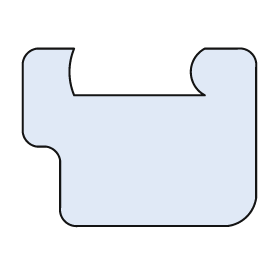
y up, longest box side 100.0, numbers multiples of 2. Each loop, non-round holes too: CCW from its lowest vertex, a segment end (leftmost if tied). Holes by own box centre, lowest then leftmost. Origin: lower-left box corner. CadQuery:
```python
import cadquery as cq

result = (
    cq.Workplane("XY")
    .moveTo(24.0, 0.0)
    .lineTo(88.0, 0.0)
    .threePointArc((96.0, 4.0), (100.0, 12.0))
    .lineTo(100.0, 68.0)
    .threePointArc((98.0, 74.0), (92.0, 76.0))
    .lineTo(78.0, 76.0)
    .threePointArc((72.0, 66.0), (78.0, 56.0))
    .lineTo(22.0, 56.0)
    .threePointArc((20.0, 66.0), (22.0, 76.0))
    .lineTo(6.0, 76.0)
    .threePointArc((2.0, 74.0), (0.0, 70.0))
    .lineTo(0.0, 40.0)
    .threePointArc((2.0, 36.0), (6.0, 34.0))
    .lineTo(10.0, 34.0)
    .threePointArc((14.0, 32.0), (16.0, 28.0))
    .lineTo(16.0, 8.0)
    .threePointArc((18.0, 2.0), (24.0, 0.0))
    .close()
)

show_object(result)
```